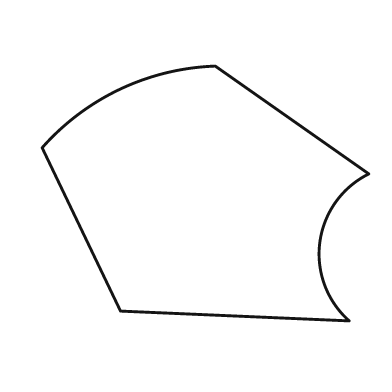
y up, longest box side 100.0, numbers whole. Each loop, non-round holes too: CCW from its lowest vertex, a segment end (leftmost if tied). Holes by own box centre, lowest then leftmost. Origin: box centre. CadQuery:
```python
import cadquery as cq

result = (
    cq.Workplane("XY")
    .moveTo(44.0, -39.0)
    .threePointArc((35.0, -15.0), (50.0, 6.0))
    .lineTo(3.0, 39.0)
    .threePointArc((-26.0, 32.0), (-50.0, 14.0))
    .lineTo(-26.0, -36.0)
    .close()
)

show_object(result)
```